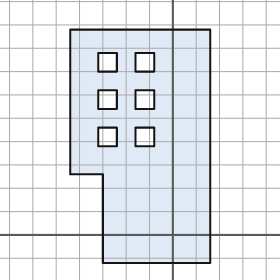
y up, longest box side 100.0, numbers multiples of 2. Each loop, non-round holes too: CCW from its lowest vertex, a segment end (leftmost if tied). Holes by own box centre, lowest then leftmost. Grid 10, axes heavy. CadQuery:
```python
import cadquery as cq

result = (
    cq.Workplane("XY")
    .moveTo(-30.0, -12.0)
    .lineTo(16.0, -12.0)
    .lineTo(16.0, 88.0)
    .lineTo(-44.0, 88.0)
    .lineTo(-44.0, 26.0)
    .lineTo(-30.0, 26.0)
    .close()
    .moveTo(-32.0, 38.0)
    .lineTo(-24.0, 38.0)
    .lineTo(-24.0, 46.0)
    .lineTo(-32.0, 46.0)
    .close()
    .moveTo(-16.0, 38.0)
    .lineTo(-8.0, 38.0)
    .lineTo(-8.0, 46.0)
    .lineTo(-16.0, 46.0)
    .close()
    .moveTo(-32.0, 54.0)
    .lineTo(-24.0, 54.0)
    .lineTo(-24.0, 62.0)
    .lineTo(-32.0, 62.0)
    .close()
    .moveTo(-16.0, 54.0)
    .lineTo(-8.0, 54.0)
    .lineTo(-8.0, 62.0)
    .lineTo(-16.0, 62.0)
    .close()
    .moveTo(-32.0, 70.0)
    .lineTo(-24.0, 70.0)
    .lineTo(-24.0, 78.0)
    .lineTo(-32.0, 78.0)
    .close()
    .moveTo(-16.0, 70.0)
    .lineTo(-8.0, 70.0)
    .lineTo(-8.0, 78.0)
    .lineTo(-16.0, 78.0)
    .close()
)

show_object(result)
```